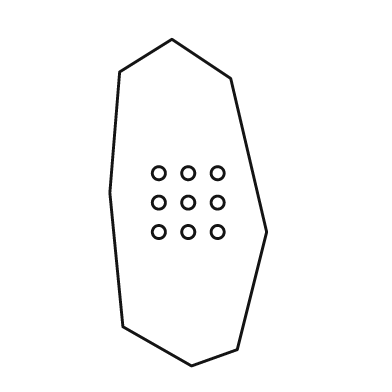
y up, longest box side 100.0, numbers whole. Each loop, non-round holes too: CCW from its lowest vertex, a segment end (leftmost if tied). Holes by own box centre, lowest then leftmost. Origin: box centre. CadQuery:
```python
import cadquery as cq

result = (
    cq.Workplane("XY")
    .moveTo(1.0, -50.0)
    .lineTo(15.0, -45.0)
    .lineTo(24.0, -9.0)
    .lineTo(13.0, 38.0)
    .lineTo(-5.0, 50.0)
    .lineTo(-21.0, 40.0)
    .lineTo(-24.0, 3.0)
    .lineTo(-20.0, -38.0)
    .close()
    .moveTo(-9.0, -9.0)
    .circle(2.0)
    .moveTo(0.0, -9.0)
    .circle(2.0)
    .moveTo(9.0, -9.0)
    .circle(2.0)
    .moveTo(-9.0, 0.0)
    .circle(2.0)
    .moveTo(0.0, 0.0)
    .circle(2.0)
    .moveTo(9.0, 0.0)
    .circle(2.0)
    .moveTo(-9.0, 9.0)
    .circle(2.0)
    .moveTo(0.0, 9.0)
    .circle(2.0)
    .moveTo(9.0, 9.0)
    .circle(2.0)
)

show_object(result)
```